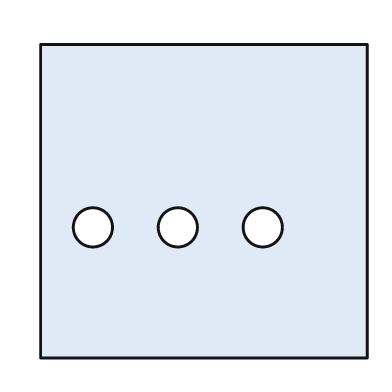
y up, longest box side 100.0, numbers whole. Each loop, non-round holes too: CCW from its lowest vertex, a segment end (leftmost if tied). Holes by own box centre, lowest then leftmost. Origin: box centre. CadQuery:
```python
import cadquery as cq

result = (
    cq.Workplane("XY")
    .moveTo(-50.0, -48.0)
    .lineTo(50.0, -48.0)
    .lineTo(50.0, 48.0)
    .lineTo(-50.0, 48.0)
    .close()
    .moveTo(-34.0, -8.0)
    .circle(6.0)
    .moveTo(-8.0, -8.0)
    .circle(6.0)
    .moveTo(18.0, -8.0)
    .circle(6.0)
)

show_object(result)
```